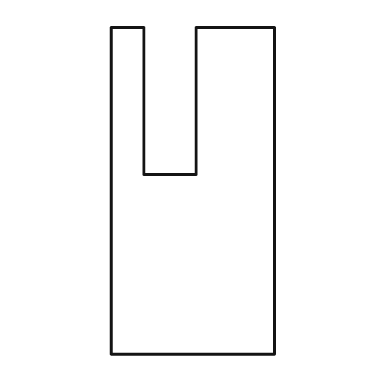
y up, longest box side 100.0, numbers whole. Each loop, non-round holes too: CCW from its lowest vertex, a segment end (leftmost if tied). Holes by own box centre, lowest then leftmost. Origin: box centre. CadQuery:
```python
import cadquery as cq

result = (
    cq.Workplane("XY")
    .moveTo(-25.0, -50.0)
    .lineTo(25.0, -50.0)
    .lineTo(25.0, 50.0)
    .lineTo(1.0, 50.0)
    .lineTo(1.0, 5.0)
    .lineTo(-15.0, 5.0)
    .lineTo(-15.0, 50.0)
    .lineTo(-25.0, 50.0)
    .close()
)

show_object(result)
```